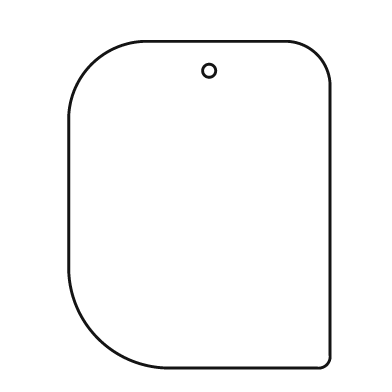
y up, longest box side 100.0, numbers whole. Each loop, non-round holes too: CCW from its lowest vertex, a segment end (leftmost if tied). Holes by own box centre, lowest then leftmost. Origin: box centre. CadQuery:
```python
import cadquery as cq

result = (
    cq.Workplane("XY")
    .moveTo(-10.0, -50.0)
    .lineTo(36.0, -50.0)
    .threePointArc((39.0, -49.0), (40.0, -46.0))
    .lineTo(40.0, 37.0)
    .threePointArc((36.0, 46.0), (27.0, 50.0))
    .lineTo(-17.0, 50.0)
    .threePointArc((-33.0, 43.0), (-40.0, 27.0))
    .lineTo(-40.0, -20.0)
    .threePointArc((-31.0, -41.0), (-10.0, -50.0))
    .close()
    .moveTo(3.0, 41.0)
    .circle(2.0)
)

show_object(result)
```